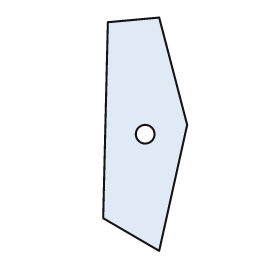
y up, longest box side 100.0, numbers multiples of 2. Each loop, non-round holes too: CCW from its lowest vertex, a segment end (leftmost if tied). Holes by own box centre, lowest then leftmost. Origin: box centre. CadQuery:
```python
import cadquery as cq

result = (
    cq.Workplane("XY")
    .moveTo(6.0, -50.0)
    .lineTo(18.0, 4.0)
    .lineTo(6.0, 50.0)
    .lineTo(-16.0, 48.0)
    .lineTo(-18.0, -36.0)
    .close()
    .moveTo(0.0, 0.0)
    .circle(4.0)
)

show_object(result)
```